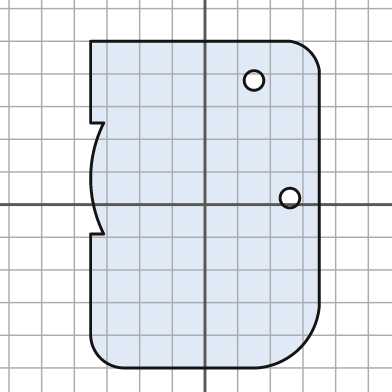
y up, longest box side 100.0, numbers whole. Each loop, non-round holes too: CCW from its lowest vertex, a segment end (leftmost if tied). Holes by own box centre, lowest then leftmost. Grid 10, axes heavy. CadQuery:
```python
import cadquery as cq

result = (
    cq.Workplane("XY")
    .moveTo(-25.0, -50.0)
    .lineTo(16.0, -50.0)
    .threePointArc((29.0, -44.0), (35.0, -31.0))
    .lineTo(35.0, 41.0)
    .threePointArc((32.0, 47.0), (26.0, 50.0))
    .lineTo(-35.0, 50.0)
    .lineTo(-35.0, 25.0)
    .lineTo(-31.0, 25.0)
    .threePointArc((-35.0, 8.0), (-31.0, -9.0))
    .lineTo(-35.0, -9.0)
    .lineTo(-35.0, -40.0)
    .threePointArc((-32.0, -47.0), (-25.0, -50.0))
    .close()
    .moveTo(26.0, 2.0)
    .circle(3.0)
    .moveTo(15.0, 38.0)
    .circle(3.0)
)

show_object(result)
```